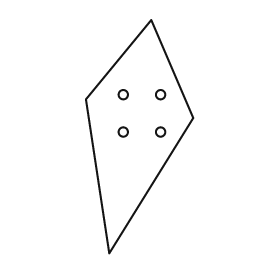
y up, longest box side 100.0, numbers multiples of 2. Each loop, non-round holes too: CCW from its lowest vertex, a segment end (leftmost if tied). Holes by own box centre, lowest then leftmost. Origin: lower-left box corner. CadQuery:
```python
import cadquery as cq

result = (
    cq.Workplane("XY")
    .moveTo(10.0, 0.0)
    .lineTo(46.0, 58.0)
    .lineTo(28.0, 100.0)
    .lineTo(0.0, 66.0)
    .close()
    .moveTo(16.0, 52.0)
    .circle(2.0)
    .moveTo(32.0, 52.0)
    .circle(2.0)
    .moveTo(16.0, 68.0)
    .circle(2.0)
    .moveTo(32.0, 68.0)
    .circle(2.0)
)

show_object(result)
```